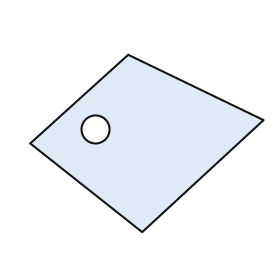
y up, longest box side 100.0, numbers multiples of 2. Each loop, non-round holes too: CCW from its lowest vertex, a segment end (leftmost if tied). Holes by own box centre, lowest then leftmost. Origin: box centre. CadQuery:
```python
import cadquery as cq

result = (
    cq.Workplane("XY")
    .moveTo(-2.0, -38.0)
    .lineTo(50.0, 10.0)
    .lineTo(-8.0, 38.0)
    .lineTo(-50.0, 0.0)
    .close()
    .moveTo(-22.0, 6.0)
    .circle(6.0)
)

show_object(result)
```